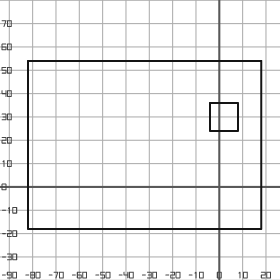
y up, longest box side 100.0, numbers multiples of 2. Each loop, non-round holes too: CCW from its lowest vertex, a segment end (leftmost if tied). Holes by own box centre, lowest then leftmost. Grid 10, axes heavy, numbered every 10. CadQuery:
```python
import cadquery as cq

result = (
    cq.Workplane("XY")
    .moveTo(-82.0, -18.0)
    .lineTo(18.0, -18.0)
    .lineTo(18.0, 54.0)
    .lineTo(-82.0, 54.0)
    .close()
    .moveTo(-4.0, 24.0)
    .lineTo(8.0, 24.0)
    .lineTo(8.0, 36.0)
    .lineTo(-4.0, 36.0)
    .close()
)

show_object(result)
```